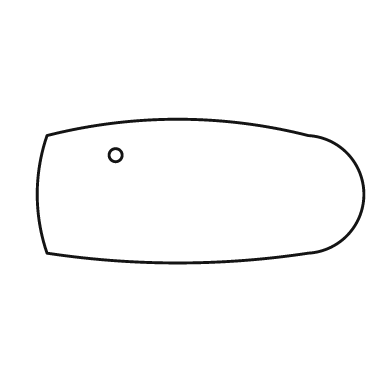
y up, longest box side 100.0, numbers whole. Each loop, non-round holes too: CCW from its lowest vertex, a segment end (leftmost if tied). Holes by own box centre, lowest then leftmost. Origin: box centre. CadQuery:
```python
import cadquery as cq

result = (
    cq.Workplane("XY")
    .moveTo(-47.0, -19.0)
    .threePointArc((-7.0, -22.0), (33.0, -19.0))
    .threePointArc((50.0, -1.0), (33.0, 17.0))
    .threePointArc((-7.0, 22.0), (-47.0, 17.0))
    .threePointArc((-50.0, -1.0), (-47.0, -19.0))
    .close()
    .moveTo(-26.0, 11.0)
    .circle(2.0)
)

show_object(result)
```